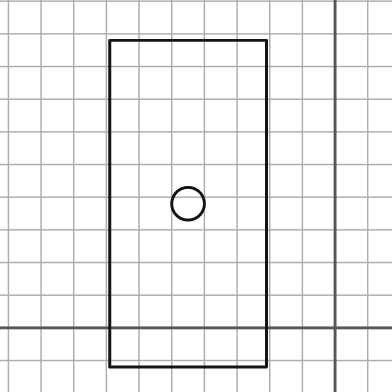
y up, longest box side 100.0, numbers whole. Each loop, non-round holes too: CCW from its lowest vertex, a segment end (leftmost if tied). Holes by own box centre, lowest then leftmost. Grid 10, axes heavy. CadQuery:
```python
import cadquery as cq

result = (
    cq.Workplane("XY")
    .moveTo(-69.0, -12.0)
    .lineTo(-21.0, -12.0)
    .lineTo(-21.0, 88.0)
    .lineTo(-69.0, 88.0)
    .close()
    .moveTo(-45.0, 38.0)
    .circle(5.0)
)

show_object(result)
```